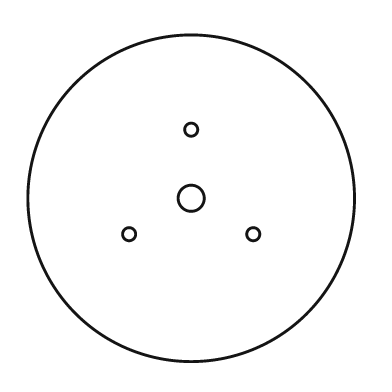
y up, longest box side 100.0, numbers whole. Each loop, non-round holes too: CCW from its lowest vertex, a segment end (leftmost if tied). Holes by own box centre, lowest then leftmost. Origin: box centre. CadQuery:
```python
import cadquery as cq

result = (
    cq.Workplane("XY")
    .moveTo(0.0, 0.0)
    .circle(50.0)
    .moveTo(-19.0, -11.0)
    .circle(2.0)
    .moveTo(19.0, -11.0)
    .circle(2.0)
    .moveTo(0.0, 0.0)
    .circle(4.0)
    .moveTo(0.0, 21.0)
    .circle(2.0)
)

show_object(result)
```